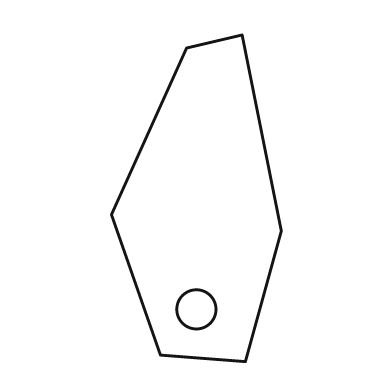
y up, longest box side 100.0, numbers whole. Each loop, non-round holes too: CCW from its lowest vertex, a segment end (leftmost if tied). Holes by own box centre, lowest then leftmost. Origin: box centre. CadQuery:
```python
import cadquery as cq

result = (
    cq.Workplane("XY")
    .moveTo(15.0, -50.0)
    .lineTo(26.0, -10.0)
    .lineTo(14.0, 50.0)
    .lineTo(-3.0, 46.0)
    .lineTo(-26.0, -5.0)
    .lineTo(-11.0, -48.0)
    .close()
    .moveTo(0.0, -34.0)
    .circle(6.0)
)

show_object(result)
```